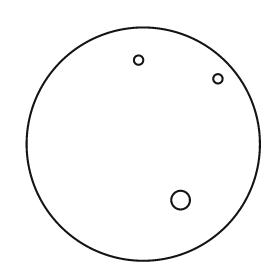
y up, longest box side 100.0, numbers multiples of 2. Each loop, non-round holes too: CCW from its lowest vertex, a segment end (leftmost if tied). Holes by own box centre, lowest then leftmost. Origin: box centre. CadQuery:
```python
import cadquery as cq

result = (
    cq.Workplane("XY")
    .moveTo(0.0, 0.0)
    .circle(50.0)
    .moveTo(16.0, -24.0)
    .circle(4.0)
    .moveTo(32.0, 28.0)
    .circle(2.0)
    .moveTo(-2.0, 36.0)
    .circle(2.0)
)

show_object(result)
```